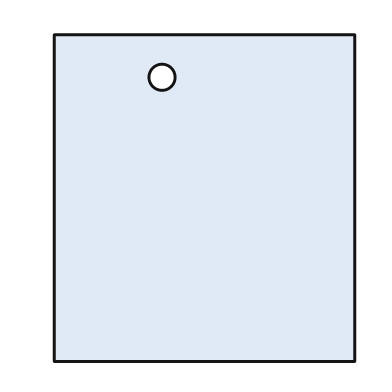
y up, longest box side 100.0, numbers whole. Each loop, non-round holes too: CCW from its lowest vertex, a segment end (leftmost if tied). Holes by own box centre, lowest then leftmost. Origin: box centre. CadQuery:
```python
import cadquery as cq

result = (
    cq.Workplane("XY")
    .moveTo(-46.0, -50.0)
    .lineTo(46.0, -50.0)
    .lineTo(46.0, 50.0)
    .lineTo(-46.0, 50.0)
    .close()
    .moveTo(-13.0, 37.0)
    .circle(4.0)
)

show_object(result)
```